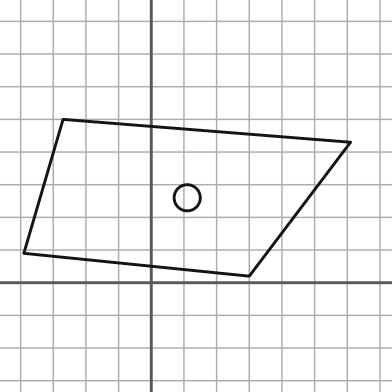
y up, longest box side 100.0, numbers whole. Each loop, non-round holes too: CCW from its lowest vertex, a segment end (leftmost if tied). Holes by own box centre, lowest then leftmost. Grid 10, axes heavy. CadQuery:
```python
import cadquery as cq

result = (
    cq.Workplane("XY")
    .moveTo(30.0, 2.0)
    .lineTo(61.0, 43.0)
    .lineTo(-27.0, 50.0)
    .lineTo(-39.0, 9.0)
    .close()
    .moveTo(11.0, 26.0)
    .circle(4.0)
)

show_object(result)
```